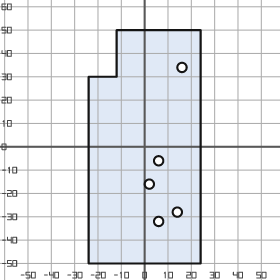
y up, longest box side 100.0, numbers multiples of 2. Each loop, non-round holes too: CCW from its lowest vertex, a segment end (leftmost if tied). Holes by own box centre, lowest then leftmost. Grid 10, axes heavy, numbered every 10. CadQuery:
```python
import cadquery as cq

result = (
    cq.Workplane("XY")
    .moveTo(-24.0, -50.0)
    .lineTo(24.0, -50.0)
    .lineTo(24.0, 50.0)
    .lineTo(-12.0, 50.0)
    .lineTo(-12.0, 30.0)
    .lineTo(-24.0, 30.0)
    .close()
    .moveTo(6.0, -32.0)
    .circle(2.0)
    .moveTo(14.0, -28.0)
    .circle(2.0)
    .moveTo(2.0, -16.0)
    .circle(2.0)
    .moveTo(6.0, -6.0)
    .circle(2.0)
    .moveTo(16.0, 34.0)
    .circle(2.0)
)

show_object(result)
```